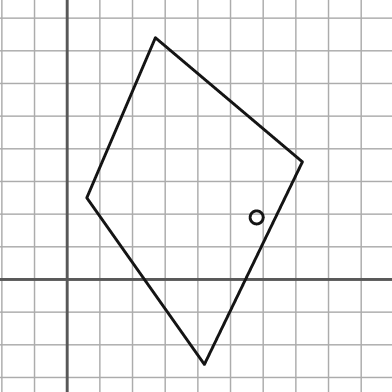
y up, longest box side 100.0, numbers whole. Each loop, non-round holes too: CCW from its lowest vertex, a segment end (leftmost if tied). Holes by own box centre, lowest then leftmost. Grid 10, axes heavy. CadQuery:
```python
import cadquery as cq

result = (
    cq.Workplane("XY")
    .moveTo(42.0, -26.0)
    .lineTo(72.0, 36.0)
    .lineTo(27.0, 74.0)
    .lineTo(6.0, 25.0)
    .close()
    .moveTo(58.0, 19.0)
    .circle(2.0)
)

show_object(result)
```